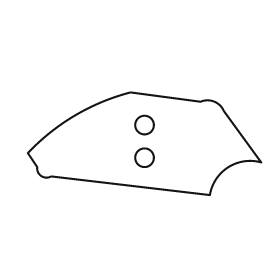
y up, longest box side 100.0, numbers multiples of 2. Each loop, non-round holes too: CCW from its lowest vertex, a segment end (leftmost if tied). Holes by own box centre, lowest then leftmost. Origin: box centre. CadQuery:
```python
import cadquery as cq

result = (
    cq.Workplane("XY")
    .moveTo(28.0, -22.0)
    .threePointArc((36.0, -10.0), (50.0, -8.0))
    .lineTo(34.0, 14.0)
    .threePointArc((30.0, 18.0), (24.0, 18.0))
    .lineTo(-6.0, 22.0)
    .threePointArc((-30.0, 12.0), (-50.0, -4.0))
    .lineTo(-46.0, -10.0)
    .threePointArc((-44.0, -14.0), (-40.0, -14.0))
    .close()
    .moveTo(0.0, -6.0)
    .circle(4.0)
    .moveTo(0.0, 8.0)
    .circle(4.0)
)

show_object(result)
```